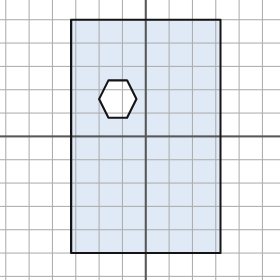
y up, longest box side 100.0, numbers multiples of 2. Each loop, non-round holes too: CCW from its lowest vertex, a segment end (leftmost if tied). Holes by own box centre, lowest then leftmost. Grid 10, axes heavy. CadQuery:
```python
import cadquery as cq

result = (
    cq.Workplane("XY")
    .moveTo(-32.0, -50.0)
    .lineTo(32.0, -50.0)
    .lineTo(32.0, 50.0)
    .lineTo(-32.0, 50.0)
    .close()
    .moveTo(-16.0, 8.0)
    .lineTo(-8.0, 8.0)
    .lineTo(-4.0, 16.0)
    .lineTo(-8.0, 24.0)
    .lineTo(-16.0, 24.0)
    .lineTo(-20.0, 16.0)
    .close()
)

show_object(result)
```